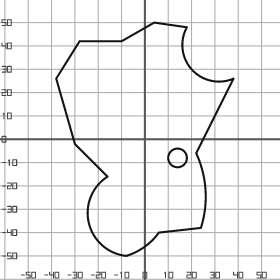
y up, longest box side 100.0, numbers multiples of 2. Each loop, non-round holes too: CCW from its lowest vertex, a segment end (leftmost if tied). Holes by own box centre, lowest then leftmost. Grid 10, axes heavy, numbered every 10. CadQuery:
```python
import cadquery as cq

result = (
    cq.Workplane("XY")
    .moveTo(-8.0, -50.0)
    .threePointArc((0.0, -46.0), (6.0, -40.0))
    .lineTo(24.0, -38.0)
    .threePointArc((26.0, -22.0), (22.0, -6.0))
    .lineTo(38.0, 26.0)
    .threePointArc((20.0, 30.0), (18.0, 48.0))
    .lineTo(4.0, 50.0)
    .lineTo(-10.0, 42.0)
    .lineTo(-28.0, 42.0)
    .lineTo(-38.0, 26.0)
    .lineTo(-30.0, -2.0)
    .lineTo(-16.0, -16.0)
    .threePointArc((-24.0, -36.0), (-8.0, -50.0))
    .close()
    .moveTo(14.0, -8.0)
    .circle(4.0)
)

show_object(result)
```